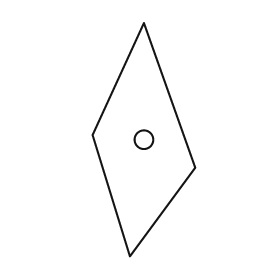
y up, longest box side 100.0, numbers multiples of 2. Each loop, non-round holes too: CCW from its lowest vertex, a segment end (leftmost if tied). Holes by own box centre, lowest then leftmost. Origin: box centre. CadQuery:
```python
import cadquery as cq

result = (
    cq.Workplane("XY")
    .moveTo(-6.0, -50.0)
    .lineTo(22.0, -12.0)
    .lineTo(0.0, 50.0)
    .lineTo(-22.0, 2.0)
    .close()
    .moveTo(0.0, 0.0)
    .circle(4.0)
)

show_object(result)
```